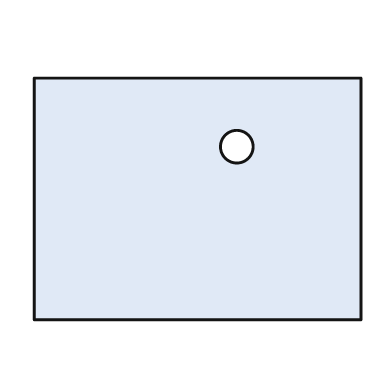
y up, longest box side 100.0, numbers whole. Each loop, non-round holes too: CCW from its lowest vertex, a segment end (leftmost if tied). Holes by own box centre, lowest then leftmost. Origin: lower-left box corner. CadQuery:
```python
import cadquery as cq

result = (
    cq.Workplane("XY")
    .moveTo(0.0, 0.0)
    .lineTo(100.0, 0.0)
    .lineTo(100.0, 74.0)
    .lineTo(0.0, 74.0)
    .close()
    .moveTo(62.0, 53.0)
    .circle(5.0)
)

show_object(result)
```